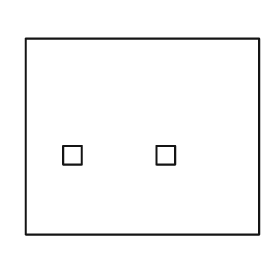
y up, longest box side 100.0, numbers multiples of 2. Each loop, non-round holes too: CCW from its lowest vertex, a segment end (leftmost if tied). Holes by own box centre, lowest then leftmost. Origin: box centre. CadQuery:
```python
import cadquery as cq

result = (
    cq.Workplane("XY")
    .moveTo(-50.0, -42.0)
    .lineTo(50.0, -42.0)
    .lineTo(50.0, 42.0)
    .lineTo(-50.0, 42.0)
    .close()
    .moveTo(-34.0, -12.0)
    .lineTo(-26.0, -12.0)
    .lineTo(-26.0, -4.0)
    .lineTo(-34.0, -4.0)
    .close()
    .moveTo(6.0, -12.0)
    .lineTo(14.0, -12.0)
    .lineTo(14.0, -4.0)
    .lineTo(6.0, -4.0)
    .close()
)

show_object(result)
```